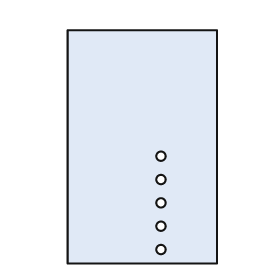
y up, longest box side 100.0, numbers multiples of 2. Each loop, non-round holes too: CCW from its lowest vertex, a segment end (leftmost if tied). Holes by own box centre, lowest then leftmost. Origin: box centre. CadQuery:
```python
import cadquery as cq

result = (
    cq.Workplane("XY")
    .moveTo(-32.0, -50.0)
    .lineTo(32.0, -50.0)
    .lineTo(32.0, 50.0)
    .lineTo(-32.0, 50.0)
    .close()
    .moveTo(8.0, -44.0)
    .circle(2.0)
    .moveTo(8.0, -34.0)
    .circle(2.0)
    .moveTo(8.0, -24.0)
    .circle(2.0)
    .moveTo(8.0, -14.0)
    .circle(2.0)
    .moveTo(8.0, -4.0)
    .circle(2.0)
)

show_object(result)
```